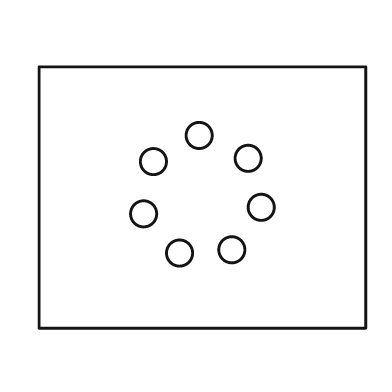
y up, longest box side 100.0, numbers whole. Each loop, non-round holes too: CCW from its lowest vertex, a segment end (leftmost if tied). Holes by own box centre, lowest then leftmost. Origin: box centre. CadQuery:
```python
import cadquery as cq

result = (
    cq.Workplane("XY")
    .moveTo(-50.0, -40.0)
    .lineTo(50.0, -40.0)
    .lineTo(50.0, 40.0)
    .lineTo(-50.0, 40.0)
    .close()
    .moveTo(-7.0, -17.0)
    .circle(4.0)
    .moveTo(9.0, -16.0)
    .circle(4.0)
    .moveTo(-18.0, -5.0)
    .circle(4.0)
    .moveTo(18.0, -3.0)
    .circle(4.0)
    .moveTo(-15.0, 11.0)
    .circle(4.0)
    .moveTo(14.0, 12.0)
    .circle(4.0)
    .moveTo(-1.0, 19.0)
    .circle(4.0)
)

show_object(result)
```